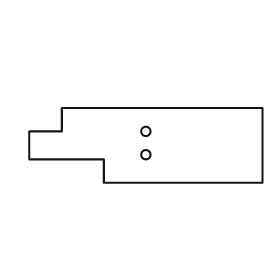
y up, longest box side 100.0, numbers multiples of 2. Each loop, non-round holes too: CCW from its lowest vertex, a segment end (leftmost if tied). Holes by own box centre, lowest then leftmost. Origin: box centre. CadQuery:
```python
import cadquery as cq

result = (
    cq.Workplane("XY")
    .moveTo(-18.0, -16.0)
    .lineTo(50.0, -16.0)
    .lineTo(50.0, 16.0)
    .lineTo(-36.0, 16.0)
    .lineTo(-36.0, 6.0)
    .lineTo(-50.0, 6.0)
    .lineTo(-50.0, -6.0)
    .lineTo(-18.0, -6.0)
    .close()
    .moveTo(0.0, -4.0)
    .circle(2.0)
    .moveTo(0.0, 6.0)
    .circle(2.0)
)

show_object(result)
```